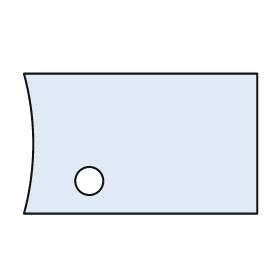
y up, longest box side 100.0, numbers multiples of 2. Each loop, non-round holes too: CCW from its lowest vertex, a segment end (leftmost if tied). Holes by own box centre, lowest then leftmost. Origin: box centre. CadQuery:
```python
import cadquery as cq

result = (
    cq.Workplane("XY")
    .moveTo(-50.0, -30.0)
    .lineTo(50.0, -30.0)
    .lineTo(50.0, 30.0)
    .lineTo(-50.0, 30.0)
    .threePointArc((-46.0, 0.0), (-50.0, -30.0))
    .close()
    .moveTo(-22.0, -16.0)
    .circle(6.0)
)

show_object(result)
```